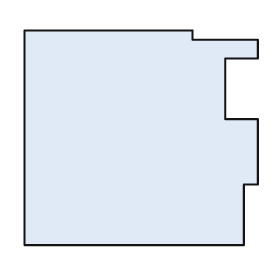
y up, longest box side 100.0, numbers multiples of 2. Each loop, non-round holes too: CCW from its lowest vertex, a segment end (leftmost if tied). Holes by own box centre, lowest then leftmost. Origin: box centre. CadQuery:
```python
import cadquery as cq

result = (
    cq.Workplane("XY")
    .moveTo(-50.0, -46.0)
    .lineTo(44.0, -46.0)
    .lineTo(44.0, -20.0)
    .lineTo(50.0, -20.0)
    .lineTo(50.0, 8.0)
    .lineTo(36.0, 8.0)
    .lineTo(36.0, 34.0)
    .lineTo(50.0, 34.0)
    .lineTo(50.0, 42.0)
    .lineTo(22.0, 42.0)
    .lineTo(22.0, 46.0)
    .lineTo(-50.0, 46.0)
    .close()
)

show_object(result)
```